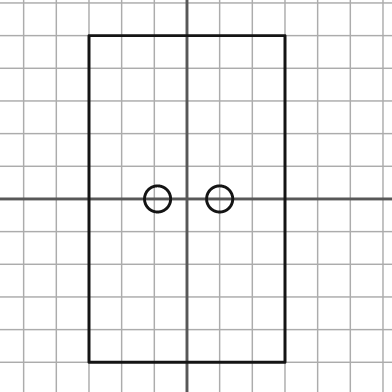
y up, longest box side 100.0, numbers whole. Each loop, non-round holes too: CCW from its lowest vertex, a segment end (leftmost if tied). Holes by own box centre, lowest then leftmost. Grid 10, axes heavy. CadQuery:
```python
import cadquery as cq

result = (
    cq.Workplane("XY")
    .moveTo(-30.0, -50.0)
    .lineTo(30.0, -50.0)
    .lineTo(30.0, 50.0)
    .lineTo(-30.0, 50.0)
    .close()
    .moveTo(-9.0, 0.0)
    .circle(4.0)
    .moveTo(10.0, 0.0)
    .circle(4.0)
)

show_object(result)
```